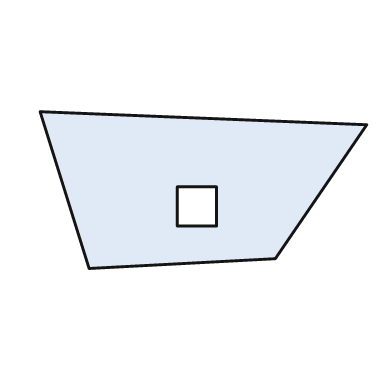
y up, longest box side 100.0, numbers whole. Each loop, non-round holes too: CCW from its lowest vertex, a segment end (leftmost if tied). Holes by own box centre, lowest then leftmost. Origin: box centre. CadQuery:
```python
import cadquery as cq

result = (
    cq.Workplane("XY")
    .moveTo(-35.0, -24.0)
    .lineTo(22.0, -21.0)
    .lineTo(50.0, 20.0)
    .lineTo(-50.0, 24.0)
    .close()
    .moveTo(-8.0, -11.0)
    .lineTo(4.0, -11.0)
    .lineTo(4.0, 1.0)
    .lineTo(-8.0, 1.0)
    .close()
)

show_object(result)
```